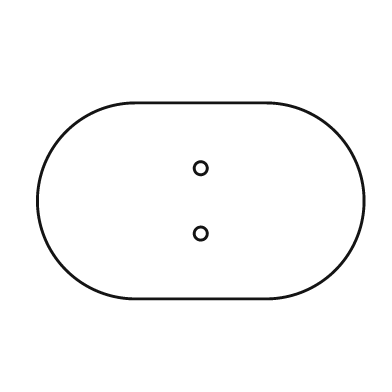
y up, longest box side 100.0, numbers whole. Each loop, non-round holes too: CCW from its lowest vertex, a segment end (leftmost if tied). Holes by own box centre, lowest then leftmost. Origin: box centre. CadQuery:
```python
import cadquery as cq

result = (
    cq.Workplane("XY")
    .moveTo(-20.0, -30.0)
    .lineTo(20.0, -30.0)
    .threePointArc((50.0, 0.0), (20.0, 30.0))
    .lineTo(-20.0, 30.0)
    .threePointArc((-50.0, 0.0), (-20.0, -30.0))
    .close()
    .moveTo(0.0, -10.0)
    .circle(2.0)
    .moveTo(0.0, 10.0)
    .circle(2.0)
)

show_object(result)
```